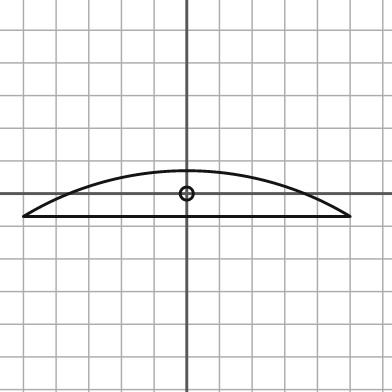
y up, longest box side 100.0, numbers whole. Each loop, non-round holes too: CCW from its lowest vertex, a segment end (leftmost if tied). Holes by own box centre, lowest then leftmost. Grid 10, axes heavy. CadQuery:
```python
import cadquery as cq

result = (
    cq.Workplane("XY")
    .moveTo(-50.0, -7.0)
    .lineTo(50.0, -7.0)
    .threePointArc((0.0, 7.0), (-50.0, -7.0))
    .close()
    .moveTo(0.0, 0.0)
    .circle(2.0)
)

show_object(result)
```